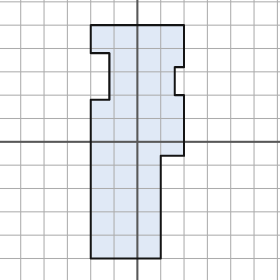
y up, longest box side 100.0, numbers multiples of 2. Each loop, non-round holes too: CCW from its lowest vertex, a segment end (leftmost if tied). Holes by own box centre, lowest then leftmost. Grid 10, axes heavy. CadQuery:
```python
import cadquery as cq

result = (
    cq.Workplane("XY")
    .moveTo(-20.0, -50.0)
    .lineTo(10.0, -50.0)
    .lineTo(10.0, -6.0)
    .lineTo(20.0, -6.0)
    .lineTo(20.0, 20.0)
    .lineTo(16.0, 20.0)
    .lineTo(16.0, 32.0)
    .lineTo(20.0, 32.0)
    .lineTo(20.0, 50.0)
    .lineTo(-20.0, 50.0)
    .lineTo(-20.0, 38.0)
    .lineTo(-12.0, 38.0)
    .lineTo(-12.0, 18.0)
    .lineTo(-20.0, 18.0)
    .close()
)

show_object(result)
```